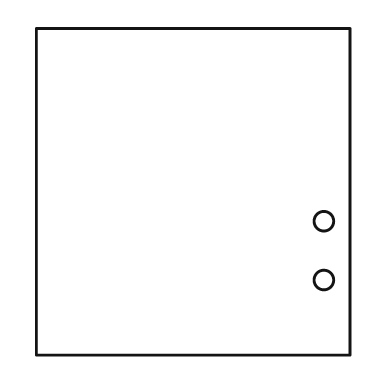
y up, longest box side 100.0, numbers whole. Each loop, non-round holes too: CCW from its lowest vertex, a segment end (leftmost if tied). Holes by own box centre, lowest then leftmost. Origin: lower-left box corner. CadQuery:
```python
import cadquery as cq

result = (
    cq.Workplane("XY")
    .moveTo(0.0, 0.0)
    .lineTo(96.0, 0.0)
    .lineTo(96.0, 100.0)
    .lineTo(0.0, 100.0)
    .close()
    .moveTo(88.0, 23.0)
    .circle(3.0)
    .moveTo(88.0, 41.0)
    .circle(3.0)
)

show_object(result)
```